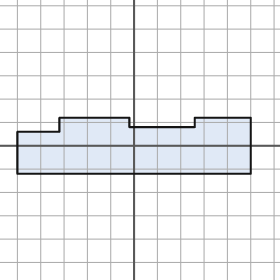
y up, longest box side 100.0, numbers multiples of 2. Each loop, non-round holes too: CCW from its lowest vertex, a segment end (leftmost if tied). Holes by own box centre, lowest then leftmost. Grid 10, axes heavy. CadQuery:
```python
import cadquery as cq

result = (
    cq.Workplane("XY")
    .moveTo(-50.0, -12.0)
    .lineTo(50.0, -12.0)
    .lineTo(50.0, 12.0)
    .lineTo(26.0, 12.0)
    .lineTo(26.0, 8.0)
    .lineTo(-2.0, 8.0)
    .lineTo(-2.0, 12.0)
    .lineTo(-32.0, 12.0)
    .lineTo(-32.0, 6.0)
    .lineTo(-50.0, 6.0)
    .close()
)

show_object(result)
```